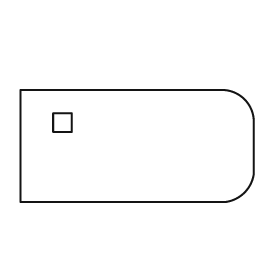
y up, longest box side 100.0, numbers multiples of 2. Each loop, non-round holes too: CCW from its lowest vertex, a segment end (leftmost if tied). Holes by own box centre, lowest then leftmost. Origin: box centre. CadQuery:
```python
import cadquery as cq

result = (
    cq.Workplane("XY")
    .moveTo(-50.0, -24.0)
    .lineTo(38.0, -24.0)
    .threePointArc((46.0, -20.0), (50.0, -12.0))
    .lineTo(50.0, 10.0)
    .threePointArc((46.0, 20.0), (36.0, 24.0))
    .lineTo(-50.0, 24.0)
    .close()
    .moveTo(-36.0, 6.0)
    .lineTo(-28.0, 6.0)
    .lineTo(-28.0, 14.0)
    .lineTo(-36.0, 14.0)
    .close()
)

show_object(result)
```